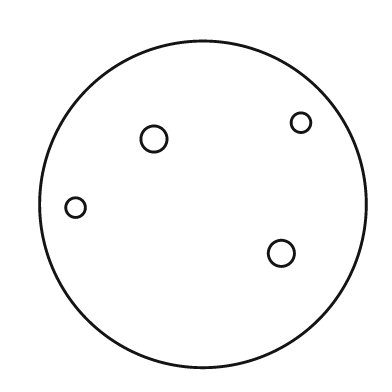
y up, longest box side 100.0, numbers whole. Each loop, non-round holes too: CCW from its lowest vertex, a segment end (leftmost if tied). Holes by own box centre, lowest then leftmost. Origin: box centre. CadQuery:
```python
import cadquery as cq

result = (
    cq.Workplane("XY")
    .moveTo(0.0, 0.0)
    .circle(50.0)
    .moveTo(24.0, -15.0)
    .circle(4.0)
    .moveTo(-39.0, -1.0)
    .circle(3.0)
    .moveTo(-15.0, 20.0)
    .circle(4.0)
    .moveTo(30.0, 25.0)
    .circle(3.0)
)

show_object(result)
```